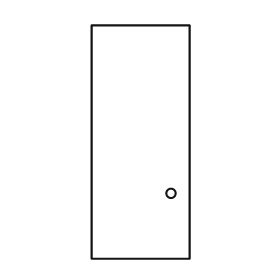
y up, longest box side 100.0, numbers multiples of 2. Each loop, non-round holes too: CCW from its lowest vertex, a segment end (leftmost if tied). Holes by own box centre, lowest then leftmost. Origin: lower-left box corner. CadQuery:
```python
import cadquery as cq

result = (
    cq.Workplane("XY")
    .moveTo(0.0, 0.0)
    .lineTo(42.0, 0.0)
    .lineTo(42.0, 100.0)
    .lineTo(0.0, 100.0)
    .close()
    .moveTo(34.0, 28.0)
    .circle(2.0)
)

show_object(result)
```